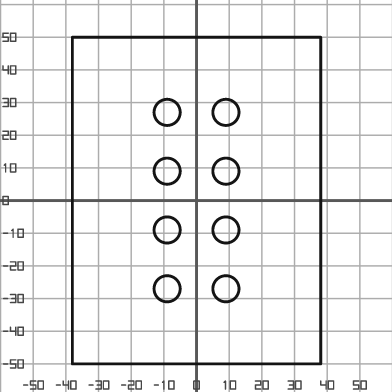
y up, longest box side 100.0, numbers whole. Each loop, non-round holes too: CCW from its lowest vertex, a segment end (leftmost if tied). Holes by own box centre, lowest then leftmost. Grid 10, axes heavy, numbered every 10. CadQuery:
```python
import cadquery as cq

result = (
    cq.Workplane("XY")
    .moveTo(-38.0, -50.0)
    .lineTo(38.0, -50.0)
    .lineTo(38.0, 50.0)
    .lineTo(-38.0, 50.0)
    .close()
    .moveTo(-9.0, -27.0)
    .circle(4.0)
    .moveTo(9.0, -27.0)
    .circle(4.0)
    .moveTo(-9.0, -9.0)
    .circle(4.0)
    .moveTo(9.0, -9.0)
    .circle(4.0)
    .moveTo(-9.0, 9.0)
    .circle(4.0)
    .moveTo(9.0, 9.0)
    .circle(4.0)
    .moveTo(-9.0, 27.0)
    .circle(4.0)
    .moveTo(9.0, 27.0)
    .circle(4.0)
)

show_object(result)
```